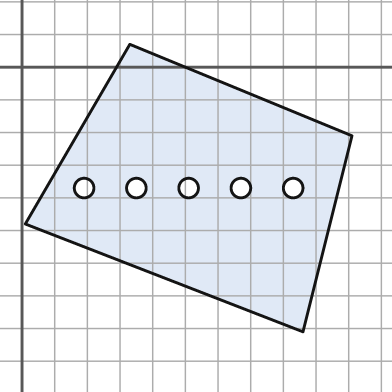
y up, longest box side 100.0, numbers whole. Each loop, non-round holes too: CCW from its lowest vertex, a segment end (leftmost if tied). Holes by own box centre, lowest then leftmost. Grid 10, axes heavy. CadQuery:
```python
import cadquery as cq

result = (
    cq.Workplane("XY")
    .moveTo(86.0, -81.0)
    .lineTo(101.0, -21.0)
    .lineTo(33.0, 7.0)
    .lineTo(1.0, -48.0)
    .close()
    .moveTo(19.0, -37.0)
    .circle(3.0)
    .moveTo(35.0, -37.0)
    .circle(3.0)
    .moveTo(51.0, -37.0)
    .circle(3.0)
    .moveTo(67.0, -37.0)
    .circle(3.0)
    .moveTo(83.0, -37.0)
    .circle(3.0)
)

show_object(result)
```